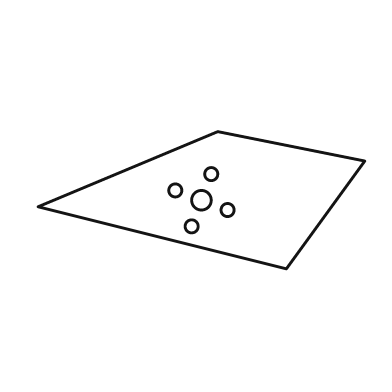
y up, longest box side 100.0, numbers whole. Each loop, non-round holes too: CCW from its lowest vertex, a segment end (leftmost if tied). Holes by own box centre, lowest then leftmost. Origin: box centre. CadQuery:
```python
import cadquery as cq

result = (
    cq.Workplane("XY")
    .moveTo(26.0, -21.0)
    .lineTo(50.0, 12.0)
    .lineTo(5.0, 21.0)
    .lineTo(-50.0, -2.0)
    .close()
    .moveTo(-3.0, -8.0)
    .circle(2.0)
    .moveTo(8.0, -3.0)
    .circle(2.0)
    .moveTo(0.0, 0.0)
    .circle(3.0)
    .moveTo(-8.0, 3.0)
    .circle(2.0)
    .moveTo(3.0, 8.0)
    .circle(2.0)
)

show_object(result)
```